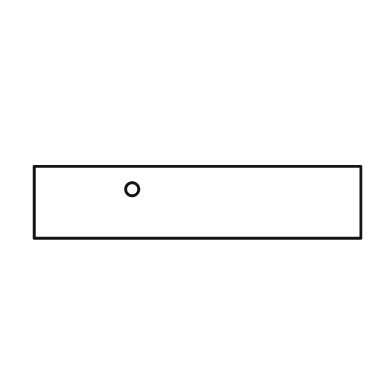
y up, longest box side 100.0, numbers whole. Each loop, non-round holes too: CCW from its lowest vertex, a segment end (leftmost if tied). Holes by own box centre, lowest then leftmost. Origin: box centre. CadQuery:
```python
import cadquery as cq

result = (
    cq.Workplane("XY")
    .moveTo(-50.0, -11.0)
    .lineTo(50.0, -11.0)
    .lineTo(50.0, 11.0)
    .lineTo(-50.0, 11.0)
    .close()
    .moveTo(-20.0, 4.0)
    .circle(2.0)
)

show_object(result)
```